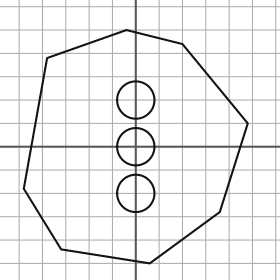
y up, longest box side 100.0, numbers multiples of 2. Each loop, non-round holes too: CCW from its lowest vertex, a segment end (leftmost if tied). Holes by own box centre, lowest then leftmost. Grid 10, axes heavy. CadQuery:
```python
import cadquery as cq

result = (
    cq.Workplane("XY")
    .moveTo(6.0, -50.0)
    .lineTo(36.0, -28.0)
    .lineTo(48.0, 10.0)
    .lineTo(20.0, 44.0)
    .lineTo(-4.0, 50.0)
    .lineTo(-38.0, 38.0)
    .lineTo(-48.0, -18.0)
    .lineTo(-32.0, -44.0)
    .close()
    .moveTo(0.0, -20.0)
    .circle(8.0)
    .moveTo(0.0, 0.0)
    .circle(8.0)
    .moveTo(0.0, 20.0)
    .circle(8.0)
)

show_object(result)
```